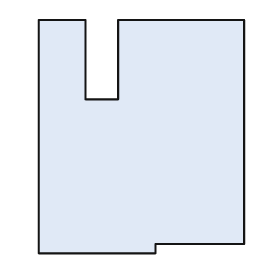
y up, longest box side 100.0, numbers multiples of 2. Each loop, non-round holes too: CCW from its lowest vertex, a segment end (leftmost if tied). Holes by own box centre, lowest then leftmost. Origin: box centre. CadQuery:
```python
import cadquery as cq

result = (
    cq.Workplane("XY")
    .moveTo(-44.0, -50.0)
    .lineTo(6.0, -50.0)
    .lineTo(6.0, -46.0)
    .lineTo(44.0, -46.0)
    .lineTo(44.0, 50.0)
    .lineTo(-10.0, 50.0)
    .lineTo(-10.0, 16.0)
    .lineTo(-24.0, 16.0)
    .lineTo(-24.0, 50.0)
    .lineTo(-44.0, 50.0)
    .close()
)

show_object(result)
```